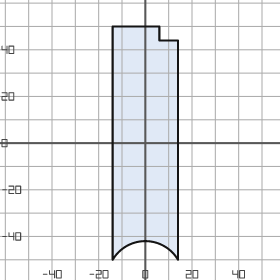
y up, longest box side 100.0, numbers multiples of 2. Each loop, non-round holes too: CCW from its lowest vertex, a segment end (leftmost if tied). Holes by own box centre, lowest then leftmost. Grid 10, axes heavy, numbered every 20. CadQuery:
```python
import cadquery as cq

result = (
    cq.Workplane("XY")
    .moveTo(-14.0, -50.0)
    .threePointArc((0.0, -42.0), (14.0, -50.0))
    .lineTo(14.0, 44.0)
    .lineTo(6.0, 44.0)
    .lineTo(6.0, 50.0)
    .lineTo(-14.0, 50.0)
    .close()
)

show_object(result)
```